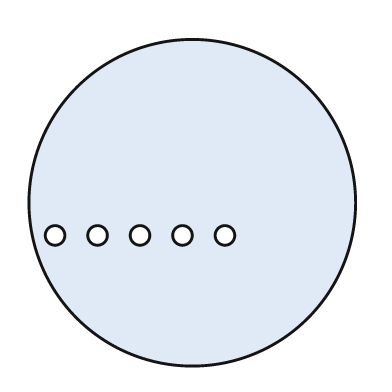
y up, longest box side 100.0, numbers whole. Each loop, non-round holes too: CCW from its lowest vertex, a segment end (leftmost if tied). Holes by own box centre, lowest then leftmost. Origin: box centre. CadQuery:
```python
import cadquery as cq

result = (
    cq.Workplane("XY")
    .moveTo(0.0, 0.0)
    .circle(50.0)
    .moveTo(-42.0, -10.0)
    .circle(3.0)
    .moveTo(-29.0, -10.0)
    .circle(3.0)
    .moveTo(-16.0, -10.0)
    .circle(3.0)
    .moveTo(-3.0, -10.0)
    .circle(3.0)
    .moveTo(10.0, -10.0)
    .circle(3.0)
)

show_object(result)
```